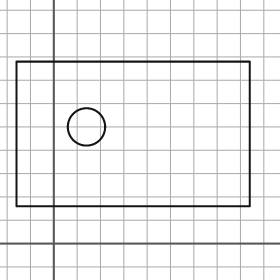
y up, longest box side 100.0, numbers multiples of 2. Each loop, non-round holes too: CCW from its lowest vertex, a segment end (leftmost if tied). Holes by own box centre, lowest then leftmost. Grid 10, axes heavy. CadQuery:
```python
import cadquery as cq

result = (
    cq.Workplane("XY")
    .moveTo(-16.0, 16.0)
    .lineTo(84.0, 16.0)
    .lineTo(84.0, 78.0)
    .lineTo(-16.0, 78.0)
    .close()
    .moveTo(14.0, 50.0)
    .circle(8.0)
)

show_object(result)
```